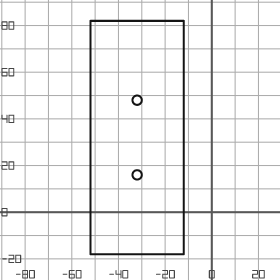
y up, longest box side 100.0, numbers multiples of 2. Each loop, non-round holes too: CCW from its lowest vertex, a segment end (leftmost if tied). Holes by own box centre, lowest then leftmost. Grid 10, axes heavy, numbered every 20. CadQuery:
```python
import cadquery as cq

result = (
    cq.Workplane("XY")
    .moveTo(-52.0, -18.0)
    .lineTo(-12.0, -18.0)
    .lineTo(-12.0, 82.0)
    .lineTo(-52.0, 82.0)
    .close()
    .moveTo(-32.0, 16.0)
    .circle(2.0)
    .moveTo(-32.0, 48.0)
    .circle(2.0)
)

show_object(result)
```